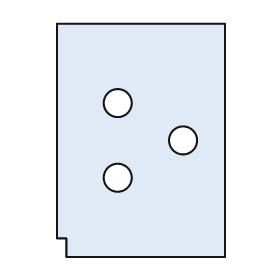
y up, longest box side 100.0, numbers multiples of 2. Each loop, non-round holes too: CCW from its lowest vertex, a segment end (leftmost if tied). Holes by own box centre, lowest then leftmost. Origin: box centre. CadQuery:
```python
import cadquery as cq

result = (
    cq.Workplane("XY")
    .moveTo(-32.0, -50.0)
    .lineTo(36.0, -50.0)
    .lineTo(36.0, 50.0)
    .lineTo(-36.0, 50.0)
    .lineTo(-36.0, -42.0)
    .lineTo(-32.0, -42.0)
    .close()
    .moveTo(-10.0, -16.0)
    .circle(6.0)
    .moveTo(18.0, 0.0)
    .circle(6.0)
    .moveTo(-10.0, 16.0)
    .circle(6.0)
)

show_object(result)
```